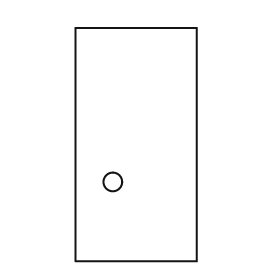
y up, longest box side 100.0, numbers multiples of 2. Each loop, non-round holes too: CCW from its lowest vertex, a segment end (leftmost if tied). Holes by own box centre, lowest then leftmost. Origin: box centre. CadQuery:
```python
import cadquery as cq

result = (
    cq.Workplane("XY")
    .moveTo(-26.0, -50.0)
    .lineTo(26.0, -50.0)
    .lineTo(26.0, 50.0)
    .lineTo(-26.0, 50.0)
    .close()
    .moveTo(-10.0, -16.0)
    .circle(4.0)
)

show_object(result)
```